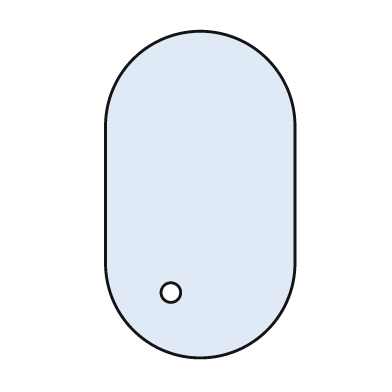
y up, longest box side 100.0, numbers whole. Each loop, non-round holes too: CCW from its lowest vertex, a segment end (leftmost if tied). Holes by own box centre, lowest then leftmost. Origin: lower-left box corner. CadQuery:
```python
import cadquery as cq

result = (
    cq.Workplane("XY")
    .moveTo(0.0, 29.0)
    .threePointArc((29.0, 0.0), (58.0, 29.0))
    .lineTo(58.0, 71.0)
    .threePointArc((29.0, 100.0), (0.0, 71.0))
    .close()
    .moveTo(20.0, 20.0)
    .circle(3.0)
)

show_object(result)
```